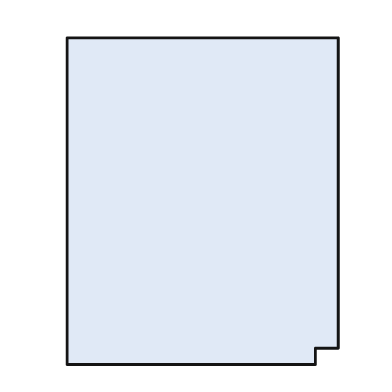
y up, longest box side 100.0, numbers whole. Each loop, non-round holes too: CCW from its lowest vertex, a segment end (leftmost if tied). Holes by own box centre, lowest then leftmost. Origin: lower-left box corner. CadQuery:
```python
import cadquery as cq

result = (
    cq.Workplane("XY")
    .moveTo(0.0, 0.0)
    .lineTo(76.0, 0.0)
    .lineTo(76.0, 5.0)
    .lineTo(83.0, 5.0)
    .lineTo(83.0, 100.0)
    .lineTo(0.0, 100.0)
    .close()
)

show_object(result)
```